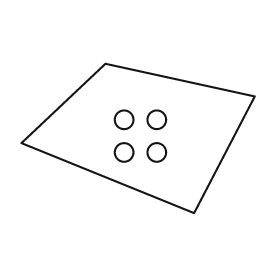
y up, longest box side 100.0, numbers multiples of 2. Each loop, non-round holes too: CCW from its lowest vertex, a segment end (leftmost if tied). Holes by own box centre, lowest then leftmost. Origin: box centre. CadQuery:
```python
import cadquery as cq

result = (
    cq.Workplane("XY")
    .moveTo(24.0, -32.0)
    .lineTo(50.0, 18.0)
    .lineTo(-14.0, 32.0)
    .lineTo(-50.0, -2.0)
    .close()
    .moveTo(-6.0, -6.0)
    .circle(4.0)
    .moveTo(8.0, -6.0)
    .circle(4.0)
    .moveTo(-6.0, 8.0)
    .circle(4.0)
    .moveTo(8.0, 8.0)
    .circle(4.0)
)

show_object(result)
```